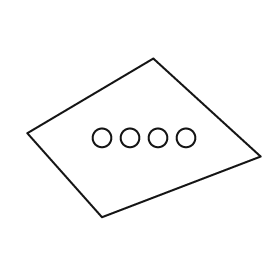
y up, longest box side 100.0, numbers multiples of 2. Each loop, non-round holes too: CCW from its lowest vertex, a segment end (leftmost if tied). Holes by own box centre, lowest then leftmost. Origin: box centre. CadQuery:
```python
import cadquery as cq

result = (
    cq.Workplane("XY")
    .moveTo(-18.0, -34.0)
    .lineTo(50.0, -8.0)
    .lineTo(4.0, 34.0)
    .lineTo(-50.0, 2.0)
    .close()
    .moveTo(-18.0, 0.0)
    .circle(4.0)
    .moveTo(-6.0, 0.0)
    .circle(4.0)
    .moveTo(6.0, 0.0)
    .circle(4.0)
    .moveTo(18.0, 0.0)
    .circle(4.0)
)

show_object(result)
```